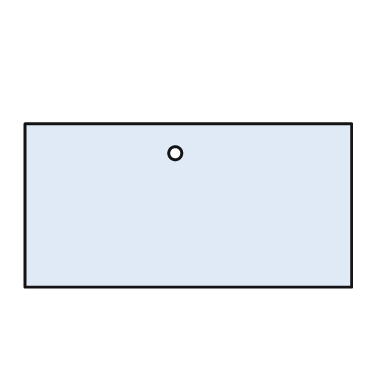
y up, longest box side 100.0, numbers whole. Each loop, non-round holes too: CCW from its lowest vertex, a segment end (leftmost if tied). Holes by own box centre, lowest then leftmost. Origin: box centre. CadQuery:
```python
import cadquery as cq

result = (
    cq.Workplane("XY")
    .moveTo(-50.0, -25.0)
    .lineTo(50.0, -25.0)
    .lineTo(50.0, 25.0)
    .lineTo(-50.0, 25.0)
    .close()
    .moveTo(-4.0, 16.0)
    .circle(2.0)
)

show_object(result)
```